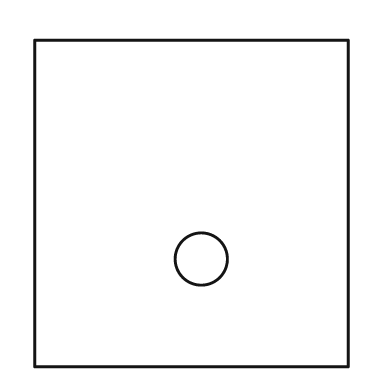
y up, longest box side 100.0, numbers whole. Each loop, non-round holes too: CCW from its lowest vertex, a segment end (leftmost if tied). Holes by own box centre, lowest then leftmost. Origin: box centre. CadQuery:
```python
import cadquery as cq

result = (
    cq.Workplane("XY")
    .moveTo(-48.0, -50.0)
    .lineTo(48.0, -50.0)
    .lineTo(48.0, 50.0)
    .lineTo(-48.0, 50.0)
    .close()
    .moveTo(3.0, -17.0)
    .circle(8.0)
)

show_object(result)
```